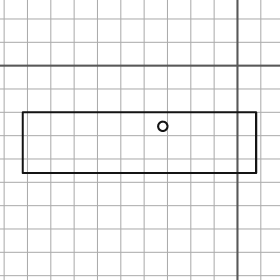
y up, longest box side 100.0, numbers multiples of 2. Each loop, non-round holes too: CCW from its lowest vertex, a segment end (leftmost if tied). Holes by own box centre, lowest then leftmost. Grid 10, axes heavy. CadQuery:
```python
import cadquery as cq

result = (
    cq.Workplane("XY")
    .moveTo(-92.0, -46.0)
    .lineTo(8.0, -46.0)
    .lineTo(8.0, -20.0)
    .lineTo(-92.0, -20.0)
    .close()
    .moveTo(-32.0, -26.0)
    .circle(2.0)
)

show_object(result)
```